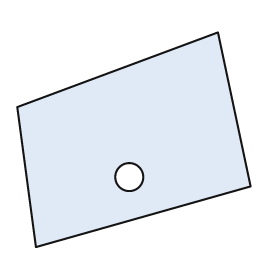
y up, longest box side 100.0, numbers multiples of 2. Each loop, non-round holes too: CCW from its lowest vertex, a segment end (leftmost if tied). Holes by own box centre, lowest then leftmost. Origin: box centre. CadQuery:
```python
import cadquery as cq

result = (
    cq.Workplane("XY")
    .moveTo(-42.0, -46.0)
    .lineTo(50.0, -20.0)
    .lineTo(36.0, 46.0)
    .lineTo(-50.0, 14.0)
    .close()
    .moveTo(-2.0, -16.0)
    .circle(6.0)
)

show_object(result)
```